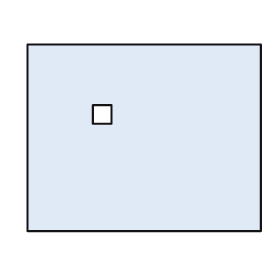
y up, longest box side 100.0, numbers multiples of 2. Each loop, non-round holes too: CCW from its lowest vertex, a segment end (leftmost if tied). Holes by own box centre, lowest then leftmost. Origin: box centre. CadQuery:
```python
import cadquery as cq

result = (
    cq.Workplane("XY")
    .moveTo(-50.0, -40.0)
    .lineTo(50.0, -40.0)
    .lineTo(50.0, 40.0)
    .lineTo(-50.0, 40.0)
    .close()
    .moveTo(-22.0, 6.0)
    .lineTo(-14.0, 6.0)
    .lineTo(-14.0, 14.0)
    .lineTo(-22.0, 14.0)
    .close()
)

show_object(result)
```